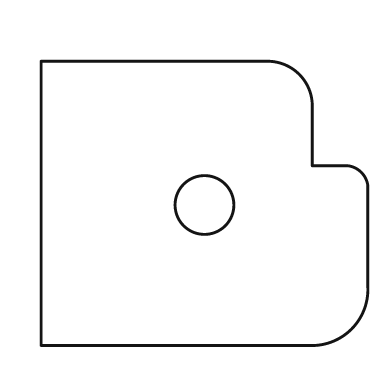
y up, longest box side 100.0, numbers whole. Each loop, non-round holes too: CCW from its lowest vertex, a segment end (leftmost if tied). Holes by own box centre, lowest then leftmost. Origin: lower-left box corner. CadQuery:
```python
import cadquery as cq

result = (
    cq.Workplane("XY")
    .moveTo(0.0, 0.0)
    .lineTo(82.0, 0.0)
    .threePointArc((95.0, 5.0), (100.0, 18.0))
    .lineTo(100.0, 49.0)
    .threePointArc((98.0, 53.0), (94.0, 55.0))
    .lineTo(83.0, 55.0)
    .lineTo(83.0, 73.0)
    .threePointArc((79.0, 83.0), (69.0, 87.0))
    .lineTo(0.0, 87.0)
    .close()
    .moveTo(50.0, 43.0)
    .circle(9.0)
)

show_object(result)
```